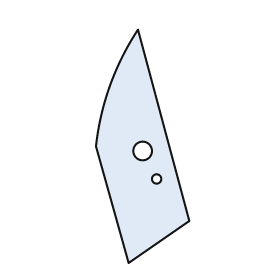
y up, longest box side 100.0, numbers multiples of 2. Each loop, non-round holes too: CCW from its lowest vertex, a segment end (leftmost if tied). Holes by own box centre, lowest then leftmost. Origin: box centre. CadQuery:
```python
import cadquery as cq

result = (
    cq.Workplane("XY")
    .moveTo(-6.0, -50.0)
    .lineTo(20.0, -32.0)
    .lineTo(-2.0, 50.0)
    .threePointArc((-14.0, 26.0), (-20.0, 0.0))
    .close()
    .moveTo(6.0, -14.0)
    .circle(2.0)
    .moveTo(0.0, -2.0)
    .circle(4.0)
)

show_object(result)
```